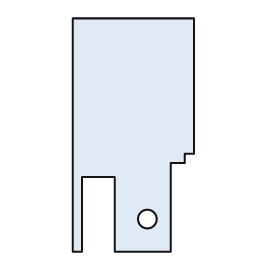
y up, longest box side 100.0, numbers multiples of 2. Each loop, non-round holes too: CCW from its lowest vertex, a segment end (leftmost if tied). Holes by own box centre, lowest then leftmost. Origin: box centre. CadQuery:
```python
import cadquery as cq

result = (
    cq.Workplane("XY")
    .moveTo(-26.0, -50.0)
    .lineTo(-22.0, -50.0)
    .lineTo(-22.0, -18.0)
    .lineTo(-8.0, -18.0)
    .lineTo(-8.0, -50.0)
    .lineTo(16.0, -50.0)
    .lineTo(16.0, -12.0)
    .lineTo(22.0, -12.0)
    .lineTo(22.0, -8.0)
    .lineTo(26.0, -8.0)
    .lineTo(26.0, 50.0)
    .lineTo(-26.0, 50.0)
    .close()
    .moveTo(6.0, -36.0)
    .circle(4.0)
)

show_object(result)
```